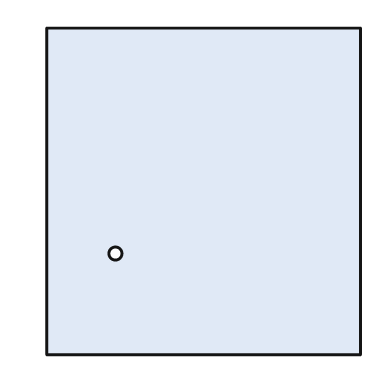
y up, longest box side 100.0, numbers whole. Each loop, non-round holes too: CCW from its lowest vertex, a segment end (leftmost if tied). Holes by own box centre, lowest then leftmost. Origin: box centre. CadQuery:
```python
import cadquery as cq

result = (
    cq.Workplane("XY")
    .moveTo(-48.0, -50.0)
    .lineTo(48.0, -50.0)
    .lineTo(48.0, 50.0)
    .lineTo(-48.0, 50.0)
    .close()
    .moveTo(-27.0, -19.0)
    .circle(2.0)
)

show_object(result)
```